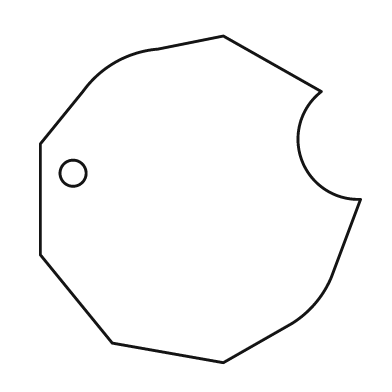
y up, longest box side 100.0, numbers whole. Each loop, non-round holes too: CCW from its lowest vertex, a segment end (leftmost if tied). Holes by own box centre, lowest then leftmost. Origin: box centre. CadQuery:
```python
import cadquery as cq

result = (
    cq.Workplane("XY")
    .moveTo(7.0, -50.0)
    .lineTo(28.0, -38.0)
    .threePointArc((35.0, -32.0), (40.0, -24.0))
    .lineTo(49.0, 0.0)
    .threePointArc((31.0, 12.0), (37.0, 33.0))
    .lineTo(7.0, 50.0)
    .lineTo(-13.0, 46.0)
    .threePointArc((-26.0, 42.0), (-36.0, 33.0))
    .lineTo(-49.0, 17.0)
    .lineTo(-49.0, -17.0)
    .lineTo(-27.0, -44.0)
    .close()
    .moveTo(-39.0, 8.0)
    .circle(4.0)
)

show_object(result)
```